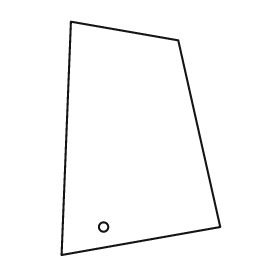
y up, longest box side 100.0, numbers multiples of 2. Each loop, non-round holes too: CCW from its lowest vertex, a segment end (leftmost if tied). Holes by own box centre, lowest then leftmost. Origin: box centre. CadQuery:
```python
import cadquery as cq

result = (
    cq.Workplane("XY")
    .moveTo(-34.0, -50.0)
    .lineTo(34.0, -38.0)
    .lineTo(16.0, 42.0)
    .lineTo(-30.0, 50.0)
    .close()
    .moveTo(-16.0, -38.0)
    .circle(2.0)
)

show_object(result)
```